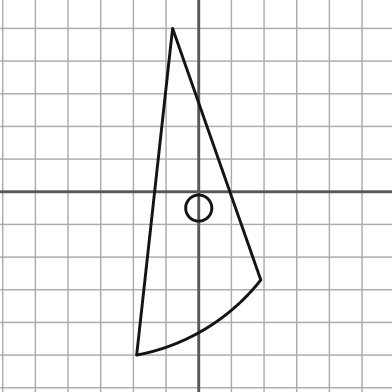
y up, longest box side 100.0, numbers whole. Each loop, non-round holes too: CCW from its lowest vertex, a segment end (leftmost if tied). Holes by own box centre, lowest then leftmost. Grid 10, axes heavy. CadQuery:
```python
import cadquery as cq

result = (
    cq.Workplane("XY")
    .moveTo(-19.0, -50.0)
    .threePointArc((2.0, -42.0), (19.0, -27.0))
    .lineTo(-8.0, 50.0)
    .close()
    .moveTo(0.0, -5.0)
    .circle(4.0)
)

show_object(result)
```